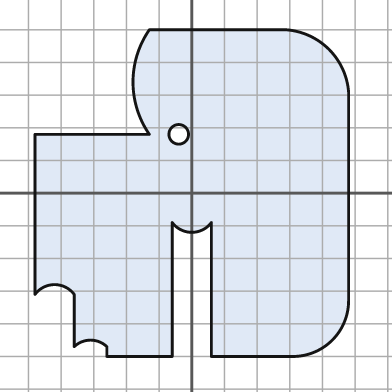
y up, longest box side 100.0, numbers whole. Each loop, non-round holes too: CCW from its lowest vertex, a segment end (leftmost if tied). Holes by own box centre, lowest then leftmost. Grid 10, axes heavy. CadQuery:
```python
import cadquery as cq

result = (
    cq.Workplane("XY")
    .moveTo(-26.0, -50.0)
    .lineTo(-6.0, -50.0)
    .lineTo(-6.0, -9.0)
    .threePointArc((0.0, -12.0), (6.0, -9.0))
    .lineTo(6.0, -50.0)
    .lineTo(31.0, -50.0)
    .threePointArc((43.0, -45.0), (48.0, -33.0))
    .lineTo(48.0, 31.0)
    .threePointArc((42.0, 44.0), (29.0, 50.0))
    .lineTo(-13.0, 50.0)
    .threePointArc((-18.0, 34.0), (-13.0, 18.0))
    .lineTo(-48.0, 18.0)
    .lineTo(-48.0, -31.0)
    .threePointArc((-42.0, -28.0), (-36.0, -31.0))
    .lineTo(-36.0, -47.0)
    .threePointArc((-31.0, -45.0), (-26.0, -47.0))
    .close()
    .moveTo(-4.0, 18.0)
    .circle(3.0)
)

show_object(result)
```